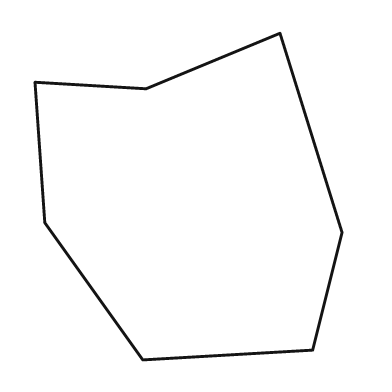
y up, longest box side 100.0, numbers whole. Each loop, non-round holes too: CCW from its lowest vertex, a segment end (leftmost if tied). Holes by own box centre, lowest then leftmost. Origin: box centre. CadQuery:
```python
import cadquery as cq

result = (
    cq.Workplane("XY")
    .moveTo(-14.0, -50.0)
    .lineTo(38.0, -47.0)
    .lineTo(47.0, -11.0)
    .lineTo(28.0, 50.0)
    .lineTo(-13.0, 33.0)
    .lineTo(-47.0, 35.0)
    .lineTo(-44.0, -8.0)
    .close()
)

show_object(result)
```